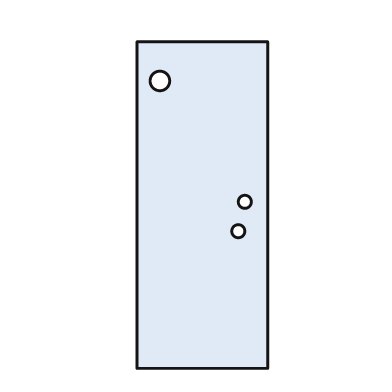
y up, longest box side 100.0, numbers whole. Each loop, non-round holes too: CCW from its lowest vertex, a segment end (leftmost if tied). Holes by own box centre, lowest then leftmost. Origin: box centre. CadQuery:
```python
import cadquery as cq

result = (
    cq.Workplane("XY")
    .moveTo(-20.0, -50.0)
    .lineTo(20.0, -50.0)
    .lineTo(20.0, 50.0)
    .lineTo(-20.0, 50.0)
    .close()
    .moveTo(11.0, -8.0)
    .circle(2.0)
    .moveTo(13.0, 1.0)
    .circle(2.0)
    .moveTo(-13.0, 38.0)
    .circle(3.0)
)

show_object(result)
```